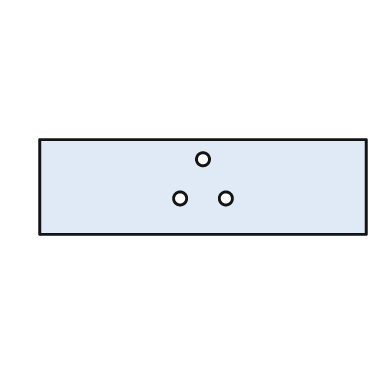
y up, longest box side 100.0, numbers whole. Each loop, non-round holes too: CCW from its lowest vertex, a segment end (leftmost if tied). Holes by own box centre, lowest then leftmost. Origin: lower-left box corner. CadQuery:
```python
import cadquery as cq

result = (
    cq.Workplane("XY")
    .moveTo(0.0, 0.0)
    .lineTo(100.0, 0.0)
    .lineTo(100.0, 29.0)
    .lineTo(0.0, 29.0)
    .close()
    .moveTo(43.0, 11.0)
    .circle(2.0)
    .moveTo(57.0, 11.0)
    .circle(2.0)
    .moveTo(50.0, 23.0)
    .circle(2.0)
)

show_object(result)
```